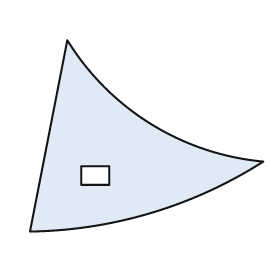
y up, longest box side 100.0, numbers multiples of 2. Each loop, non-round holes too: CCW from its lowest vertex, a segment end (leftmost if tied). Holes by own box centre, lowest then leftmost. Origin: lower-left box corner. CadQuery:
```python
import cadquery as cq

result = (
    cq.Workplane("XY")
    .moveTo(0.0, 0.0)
    .threePointArc((52.0, 8.0), (100.0, 30.0))
    .threePointArc((52.0, 46.0), (16.0, 82.0))
    .close()
    .moveTo(22.0, 20.0)
    .lineTo(34.0, 20.0)
    .lineTo(34.0, 28.0)
    .lineTo(22.0, 28.0)
    .close()
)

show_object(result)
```